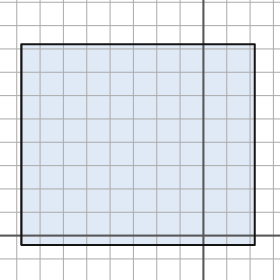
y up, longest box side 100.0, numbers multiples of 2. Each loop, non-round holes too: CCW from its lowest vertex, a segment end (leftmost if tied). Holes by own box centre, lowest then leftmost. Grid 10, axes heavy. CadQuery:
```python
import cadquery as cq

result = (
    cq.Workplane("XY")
    .moveTo(-78.0, -4.0)
    .lineTo(22.0, -4.0)
    .lineTo(22.0, 82.0)
    .lineTo(-78.0, 82.0)
    .close()
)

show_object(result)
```